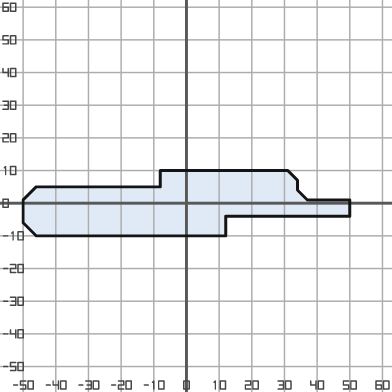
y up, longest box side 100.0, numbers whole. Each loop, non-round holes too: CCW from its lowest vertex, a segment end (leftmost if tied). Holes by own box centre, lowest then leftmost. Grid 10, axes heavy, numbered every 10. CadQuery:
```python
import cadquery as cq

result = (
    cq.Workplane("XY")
    .moveTo(-46.0, -10.0)
    .lineTo(12.0, -10.0)
    .lineTo(12.0, -4.0)
    .lineTo(50.0, -4.0)
    .lineTo(50.0, 1.0)
    .lineTo(37.0, 1.0)
    .lineTo(34.0, 4.0)
    .lineTo(34.0, 7.0)
    .lineTo(31.0, 10.0)
    .lineTo(-8.0, 10.0)
    .lineTo(-8.0, 5.0)
    .lineTo(-46.0, 5.0)
    .lineTo(-50.0, 1.0)
    .lineTo(-50.0, -6.0)
    .close()
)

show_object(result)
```